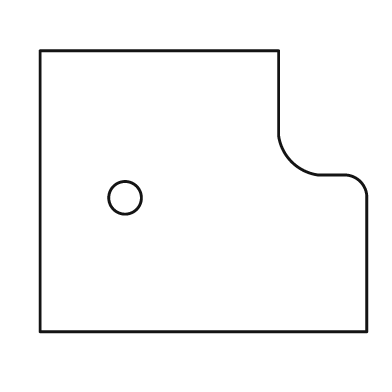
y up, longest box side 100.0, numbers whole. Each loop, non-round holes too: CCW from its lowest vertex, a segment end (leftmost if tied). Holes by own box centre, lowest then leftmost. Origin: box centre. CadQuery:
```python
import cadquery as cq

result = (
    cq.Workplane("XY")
    .moveTo(-50.0, -43.0)
    .lineTo(50.0, -43.0)
    .lineTo(50.0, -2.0)
    .threePointArc((48.0, 3.0), (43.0, 5.0))
    .lineTo(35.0, 5.0)
    .threePointArc((27.0, 9.0), (23.0, 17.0))
    .lineTo(23.0, 43.0)
    .lineTo(-50.0, 43.0)
    .close()
    .moveTo(-24.0, -2.0)
    .circle(5.0)
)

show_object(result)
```